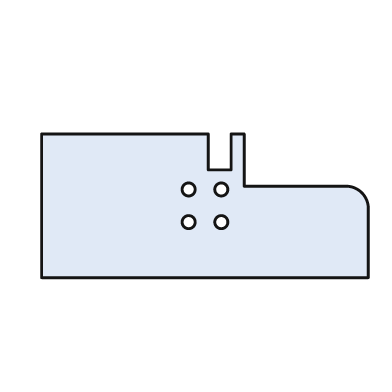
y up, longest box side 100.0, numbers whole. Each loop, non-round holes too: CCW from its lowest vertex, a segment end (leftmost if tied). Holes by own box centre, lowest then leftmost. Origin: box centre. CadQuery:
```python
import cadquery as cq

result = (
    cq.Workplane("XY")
    .moveTo(-50.0, -22.0)
    .lineTo(50.0, -22.0)
    .lineTo(50.0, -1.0)
    .threePointArc((48.0, 4.0), (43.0, 6.0))
    .lineTo(12.0, 6.0)
    .lineTo(12.0, 22.0)
    .lineTo(8.0, 22.0)
    .lineTo(8.0, 11.0)
    .lineTo(1.0, 11.0)
    .lineTo(1.0, 22.0)
    .lineTo(-50.0, 22.0)
    .close()
    .moveTo(-5.0, -5.0)
    .circle(2.0)
    .moveTo(5.0, -5.0)
    .circle(2.0)
    .moveTo(-5.0, 5.0)
    .circle(2.0)
    .moveTo(5.0, 5.0)
    .circle(2.0)
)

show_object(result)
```